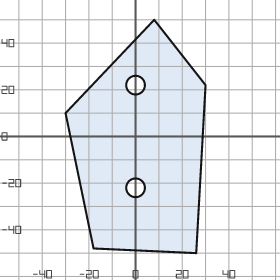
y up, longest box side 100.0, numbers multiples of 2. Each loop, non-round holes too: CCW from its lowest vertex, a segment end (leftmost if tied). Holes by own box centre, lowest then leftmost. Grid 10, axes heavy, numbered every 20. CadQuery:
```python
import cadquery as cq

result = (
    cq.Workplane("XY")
    .moveTo(26.0, -50.0)
    .lineTo(30.0, 22.0)
    .lineTo(8.0, 50.0)
    .lineTo(-30.0, 10.0)
    .lineTo(-18.0, -48.0)
    .close()
    .moveTo(0.0, -22.0)
    .circle(4.0)
    .moveTo(0.0, 22.0)
    .circle(4.0)
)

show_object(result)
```